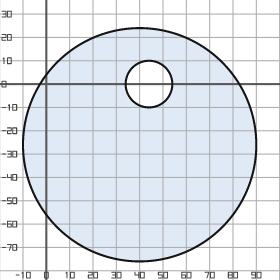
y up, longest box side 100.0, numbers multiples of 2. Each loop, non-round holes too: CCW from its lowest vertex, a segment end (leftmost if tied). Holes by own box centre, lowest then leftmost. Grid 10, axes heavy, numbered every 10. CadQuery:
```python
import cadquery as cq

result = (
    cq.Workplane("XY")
    .moveTo(40.0, -26.0)
    .circle(50.0)
    .moveTo(44.0, 0.0)
    .circle(10.0)
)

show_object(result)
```